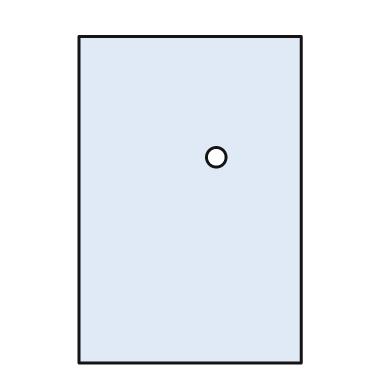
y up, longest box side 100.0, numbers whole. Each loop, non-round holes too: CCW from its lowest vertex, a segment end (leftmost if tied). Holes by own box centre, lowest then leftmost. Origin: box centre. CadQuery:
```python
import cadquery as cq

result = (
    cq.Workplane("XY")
    .moveTo(-34.0, -50.0)
    .lineTo(34.0, -50.0)
    .lineTo(34.0, 50.0)
    .lineTo(-34.0, 50.0)
    .close()
    .moveTo(8.0, 13.0)
    .circle(3.0)
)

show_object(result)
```